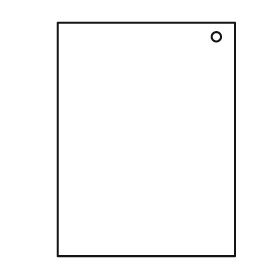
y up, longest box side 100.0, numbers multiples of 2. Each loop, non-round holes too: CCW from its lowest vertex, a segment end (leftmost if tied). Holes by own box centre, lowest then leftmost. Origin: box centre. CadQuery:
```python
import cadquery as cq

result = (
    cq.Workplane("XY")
    .moveTo(-38.0, -50.0)
    .lineTo(38.0, -50.0)
    .lineTo(38.0, 50.0)
    .lineTo(-38.0, 50.0)
    .close()
    .moveTo(30.0, 44.0)
    .circle(2.0)
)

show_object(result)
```